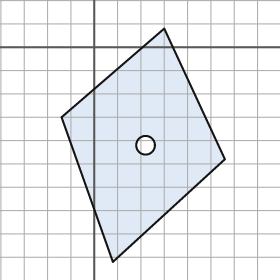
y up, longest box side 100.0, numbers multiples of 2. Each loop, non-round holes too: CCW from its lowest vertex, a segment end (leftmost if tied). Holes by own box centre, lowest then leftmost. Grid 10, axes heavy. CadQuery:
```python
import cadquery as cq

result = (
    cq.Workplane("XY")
    .moveTo(8.0, -92.0)
    .lineTo(56.0, -48.0)
    .lineTo(30.0, 8.0)
    .lineTo(-14.0, -30.0)
    .close()
    .moveTo(22.0, -42.0)
    .circle(4.0)
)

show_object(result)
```